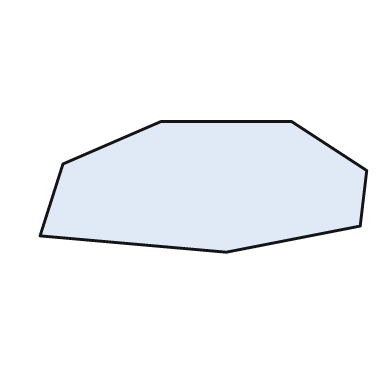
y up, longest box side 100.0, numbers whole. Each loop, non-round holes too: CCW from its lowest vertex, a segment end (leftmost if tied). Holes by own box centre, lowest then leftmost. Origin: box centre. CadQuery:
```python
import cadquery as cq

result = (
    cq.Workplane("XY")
    .moveTo(7.0, -20.0)
    .lineTo(48.0, -12.0)
    .lineTo(50.0, 5.0)
    .lineTo(27.0, 20.0)
    .lineTo(-13.0, 20.0)
    .lineTo(-43.0, 7.0)
    .lineTo(-50.0, -15.0)
    .close()
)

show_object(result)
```